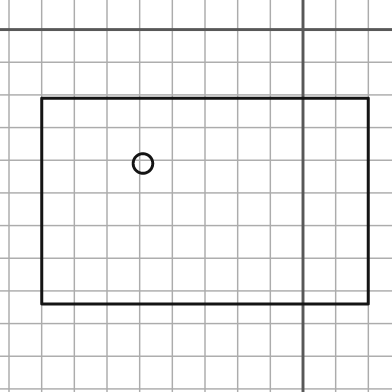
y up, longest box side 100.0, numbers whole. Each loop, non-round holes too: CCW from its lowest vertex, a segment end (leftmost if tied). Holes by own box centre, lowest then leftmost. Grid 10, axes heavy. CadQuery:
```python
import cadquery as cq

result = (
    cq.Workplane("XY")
    .moveTo(-80.0, -84.0)
    .lineTo(20.0, -84.0)
    .lineTo(20.0, -21.0)
    .lineTo(-80.0, -21.0)
    .close()
    .moveTo(-49.0, -41.0)
    .circle(3.0)
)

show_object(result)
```